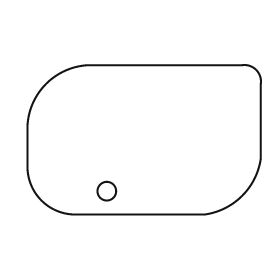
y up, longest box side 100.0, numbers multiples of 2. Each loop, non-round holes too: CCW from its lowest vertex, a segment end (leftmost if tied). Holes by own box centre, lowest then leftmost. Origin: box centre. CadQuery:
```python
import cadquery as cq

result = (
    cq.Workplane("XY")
    .moveTo(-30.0, -32.0)
    .lineTo(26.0, -32.0)
    .threePointArc((42.0, -24.0), (50.0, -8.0))
    .lineTo(50.0, 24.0)
    .threePointArc((48.0, 30.0), (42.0, 32.0))
    .lineTo(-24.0, 32.0)
    .threePointArc((-42.0, 24.0), (-50.0, 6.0))
    .lineTo(-50.0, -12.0)
    .threePointArc((-44.0, -26.0), (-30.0, -32.0))
    .close()
    .moveTo(-16.0, -22.0)
    .circle(4.0)
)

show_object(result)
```